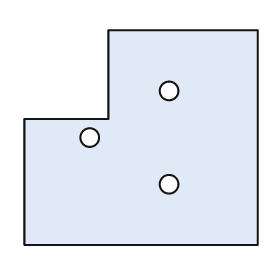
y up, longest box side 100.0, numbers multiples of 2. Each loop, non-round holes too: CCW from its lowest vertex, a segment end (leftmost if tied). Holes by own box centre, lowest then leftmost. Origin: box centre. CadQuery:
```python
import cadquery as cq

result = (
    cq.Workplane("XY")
    .moveTo(-50.0, -46.0)
    .lineTo(50.0, -46.0)
    .lineTo(50.0, 46.0)
    .lineTo(-14.0, 46.0)
    .lineTo(-14.0, 8.0)
    .lineTo(-50.0, 8.0)
    .close()
    .moveTo(12.0, -20.0)
    .circle(4.0)
    .moveTo(-22.0, 0.0)
    .circle(4.0)
    .moveTo(12.0, 20.0)
    .circle(4.0)
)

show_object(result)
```